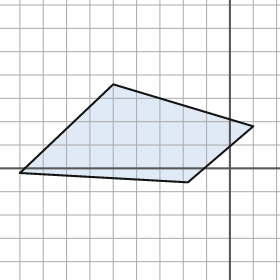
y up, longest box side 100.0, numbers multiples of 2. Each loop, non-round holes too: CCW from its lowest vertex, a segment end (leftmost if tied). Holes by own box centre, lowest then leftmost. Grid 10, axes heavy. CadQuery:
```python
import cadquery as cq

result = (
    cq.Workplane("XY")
    .moveTo(-18.0, -6.0)
    .lineTo(10.0, 18.0)
    .lineTo(-50.0, 36.0)
    .lineTo(-90.0, -2.0)
    .close()
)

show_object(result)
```